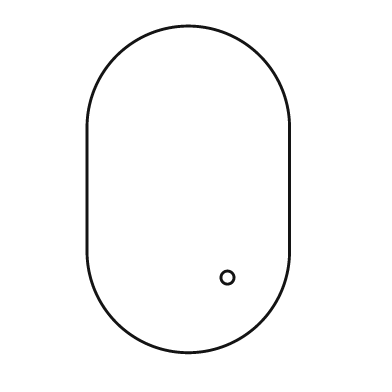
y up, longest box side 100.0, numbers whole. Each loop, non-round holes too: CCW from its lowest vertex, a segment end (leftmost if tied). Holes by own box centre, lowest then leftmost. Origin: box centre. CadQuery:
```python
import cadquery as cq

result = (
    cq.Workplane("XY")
    .moveTo(-31.0, -19.0)
    .threePointArc((0.0, -50.0), (31.0, -19.0))
    .lineTo(31.0, 19.0)
    .threePointArc((0.0, 50.0), (-31.0, 19.0))
    .close()
    .moveTo(12.0, -27.0)
    .circle(2.0)
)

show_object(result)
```